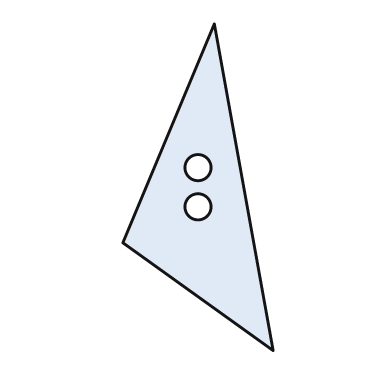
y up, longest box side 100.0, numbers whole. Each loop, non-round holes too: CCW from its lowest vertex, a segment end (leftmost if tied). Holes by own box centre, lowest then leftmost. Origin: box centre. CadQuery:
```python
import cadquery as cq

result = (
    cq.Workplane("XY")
    .moveTo(23.0, -50.0)
    .lineTo(5.0, 50.0)
    .lineTo(-23.0, -17.0)
    .close()
    .moveTo(0.0, -6.0)
    .circle(4.0)
    .moveTo(0.0, 6.0)
    .circle(4.0)
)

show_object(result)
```